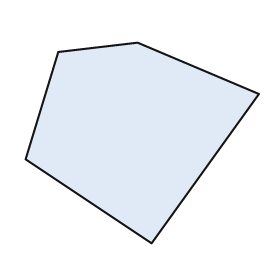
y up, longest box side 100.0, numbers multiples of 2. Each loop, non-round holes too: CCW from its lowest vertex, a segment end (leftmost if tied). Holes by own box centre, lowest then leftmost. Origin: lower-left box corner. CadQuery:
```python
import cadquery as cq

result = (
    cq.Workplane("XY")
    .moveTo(54.0, 0.0)
    .lineTo(100.0, 64.0)
    .lineTo(48.0, 86.0)
    .lineTo(14.0, 82.0)
    .lineTo(0.0, 36.0)
    .close()
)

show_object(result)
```